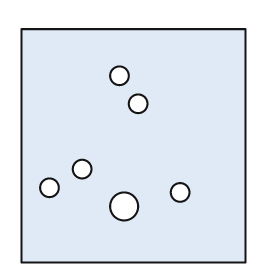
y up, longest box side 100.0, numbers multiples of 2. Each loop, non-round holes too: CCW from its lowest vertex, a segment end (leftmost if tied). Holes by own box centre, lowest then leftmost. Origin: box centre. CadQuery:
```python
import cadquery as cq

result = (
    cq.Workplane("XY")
    .moveTo(-48.0, -50.0)
    .lineTo(48.0, -50.0)
    .lineTo(48.0, 50.0)
    .lineTo(-48.0, 50.0)
    .close()
    .moveTo(-4.0, -26.0)
    .circle(6.0)
    .moveTo(20.0, -20.0)
    .circle(4.0)
    .moveTo(-36.0, -18.0)
    .circle(4.0)
    .moveTo(-22.0, -10.0)
    .circle(4.0)
    .moveTo(2.0, 18.0)
    .circle(4.0)
    .moveTo(-6.0, 30.0)
    .circle(4.0)
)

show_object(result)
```